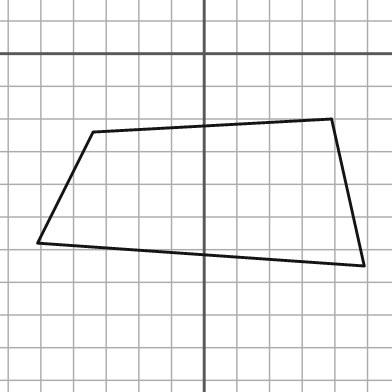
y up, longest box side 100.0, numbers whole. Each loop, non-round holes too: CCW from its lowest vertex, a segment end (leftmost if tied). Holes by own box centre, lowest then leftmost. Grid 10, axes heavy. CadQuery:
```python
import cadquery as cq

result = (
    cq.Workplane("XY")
    .moveTo(49.0, -65.0)
    .lineTo(39.0, -20.0)
    .lineTo(-34.0, -24.0)
    .lineTo(-51.0, -58.0)
    .close()
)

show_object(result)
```